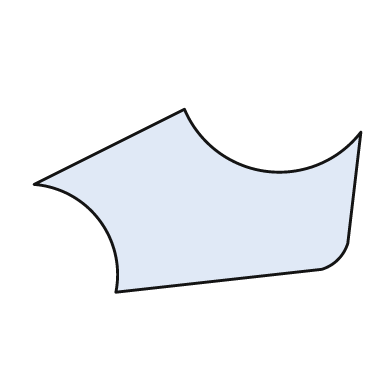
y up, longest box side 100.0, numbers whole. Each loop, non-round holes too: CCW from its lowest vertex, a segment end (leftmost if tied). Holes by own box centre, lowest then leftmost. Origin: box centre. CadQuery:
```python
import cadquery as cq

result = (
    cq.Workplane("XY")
    .moveTo(-25.0, -28.0)
    .lineTo(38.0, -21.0)
    .threePointArc((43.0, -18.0), (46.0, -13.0))
    .lineTo(50.0, 21.0)
    .threePointArc((21.0, 9.0), (-4.0, 28.0))
    .lineTo(-50.0, 5.0)
    .threePointArc((-30.0, -6.0), (-25.0, -28.0))
    .close()
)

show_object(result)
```